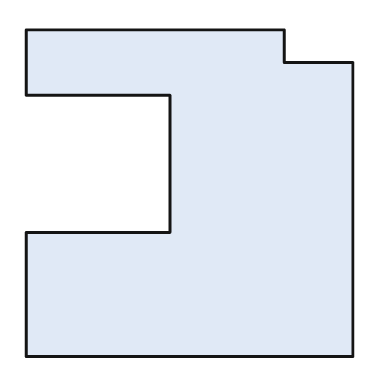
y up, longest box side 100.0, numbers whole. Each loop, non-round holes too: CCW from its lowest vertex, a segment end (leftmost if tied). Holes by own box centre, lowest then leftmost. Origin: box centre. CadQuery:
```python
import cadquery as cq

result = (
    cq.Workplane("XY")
    .moveTo(-50.0, -50.0)
    .lineTo(50.0, -50.0)
    .lineTo(50.0, 40.0)
    .lineTo(29.0, 40.0)
    .lineTo(29.0, 50.0)
    .lineTo(-50.0, 50.0)
    .lineTo(-50.0, 30.0)
    .lineTo(-6.0, 30.0)
    .lineTo(-6.0, -12.0)
    .lineTo(-50.0, -12.0)
    .close()
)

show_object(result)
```